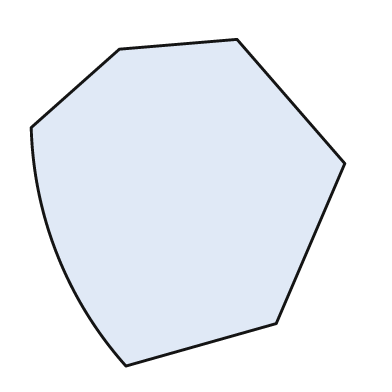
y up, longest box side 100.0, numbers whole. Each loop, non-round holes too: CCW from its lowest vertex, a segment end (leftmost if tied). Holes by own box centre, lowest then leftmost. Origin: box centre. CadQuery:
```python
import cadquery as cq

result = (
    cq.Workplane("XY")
    .moveTo(-19.0, -50.0)
    .lineTo(27.0, -37.0)
    .lineTo(48.0, 12.0)
    .lineTo(15.0, 50.0)
    .lineTo(-21.0, 47.0)
    .lineTo(-48.0, 23.0)
    .threePointArc((-40.0, -16.0), (-19.0, -50.0))
    .close()
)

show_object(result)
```